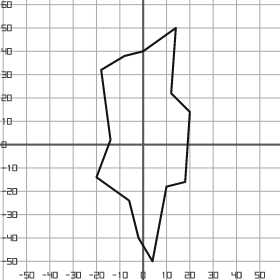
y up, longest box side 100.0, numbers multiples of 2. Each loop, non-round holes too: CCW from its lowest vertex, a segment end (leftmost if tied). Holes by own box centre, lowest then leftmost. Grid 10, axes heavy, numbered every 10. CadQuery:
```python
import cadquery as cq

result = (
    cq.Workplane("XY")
    .moveTo(4.0, -50.0)
    .lineTo(10.0, -18.0)
    .lineTo(18.0, -16.0)
    .lineTo(20.0, 14.0)
    .lineTo(12.0, 22.0)
    .lineTo(14.0, 50.0)
    .lineTo(0.0, 40.0)
    .lineTo(-8.0, 38.0)
    .lineTo(-18.0, 32.0)
    .lineTo(-14.0, 2.0)
    .lineTo(-20.0, -14.0)
    .lineTo(-6.0, -24.0)
    .lineTo(-2.0, -40.0)
    .close()
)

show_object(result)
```